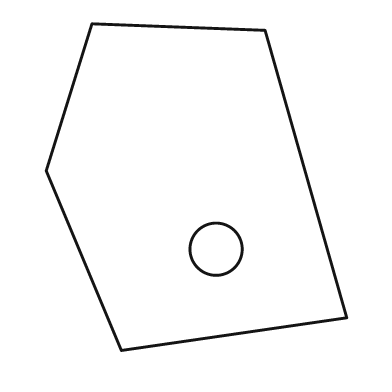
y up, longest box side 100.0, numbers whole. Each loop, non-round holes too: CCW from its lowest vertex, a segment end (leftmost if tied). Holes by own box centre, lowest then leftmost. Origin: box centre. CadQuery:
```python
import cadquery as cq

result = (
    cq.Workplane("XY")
    .moveTo(-23.0, -50.0)
    .lineTo(46.0, -40.0)
    .lineTo(21.0, 48.0)
    .lineTo(-32.0, 50.0)
    .lineTo(-46.0, 5.0)
    .close()
    .moveTo(6.0, -19.0)
    .circle(8.0)
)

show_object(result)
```